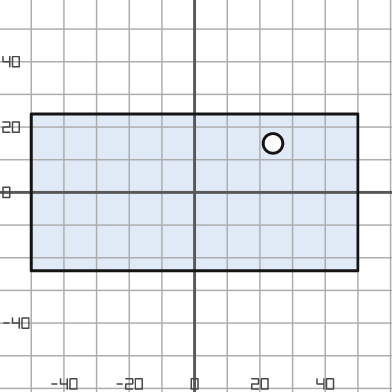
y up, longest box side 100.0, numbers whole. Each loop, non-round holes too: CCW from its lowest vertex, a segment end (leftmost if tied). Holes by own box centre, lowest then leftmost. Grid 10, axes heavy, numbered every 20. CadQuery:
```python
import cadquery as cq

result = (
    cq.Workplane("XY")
    .moveTo(-50.0, -24.0)
    .lineTo(50.0, -24.0)
    .lineTo(50.0, 24.0)
    .lineTo(-50.0, 24.0)
    .close()
    .moveTo(24.0, 15.0)
    .circle(3.0)
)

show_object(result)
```